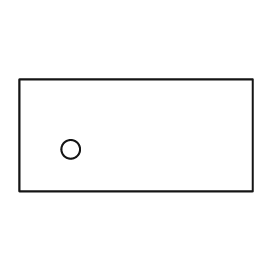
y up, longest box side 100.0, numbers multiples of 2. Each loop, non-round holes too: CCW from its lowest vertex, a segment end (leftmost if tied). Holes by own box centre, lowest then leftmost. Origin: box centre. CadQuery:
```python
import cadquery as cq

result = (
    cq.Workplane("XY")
    .moveTo(-50.0, -24.0)
    .lineTo(50.0, -24.0)
    .lineTo(50.0, 24.0)
    .lineTo(-50.0, 24.0)
    .close()
    .moveTo(-28.0, -6.0)
    .circle(4.0)
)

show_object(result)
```